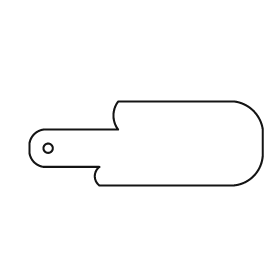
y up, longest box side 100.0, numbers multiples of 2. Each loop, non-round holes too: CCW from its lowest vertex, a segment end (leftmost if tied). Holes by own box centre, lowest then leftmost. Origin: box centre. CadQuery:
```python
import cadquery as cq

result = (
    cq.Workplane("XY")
    .moveTo(-20.0, -18.0)
    .lineTo(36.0, -18.0)
    .threePointArc((46.0, -14.0), (50.0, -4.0))
    .lineTo(50.0, 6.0)
    .threePointArc((46.0, 14.0), (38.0, 18.0))
    .lineTo(-12.0, 18.0)
    .threePointArc((-14.0, 12.0), (-12.0, 6.0))
    .lineTo(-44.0, 6.0)
    .threePointArc((-48.0, 4.0), (-50.0, 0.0))
    .lineTo(-50.0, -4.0)
    .threePointArc((-48.0, -8.0), (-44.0, -10.0))
    .lineTo(-20.0, -10.0)
    .threePointArc((-22.0, -14.0), (-20.0, -18.0))
    .close()
    .moveTo(-42.0, -2.0)
    .circle(2.0)
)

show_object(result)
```